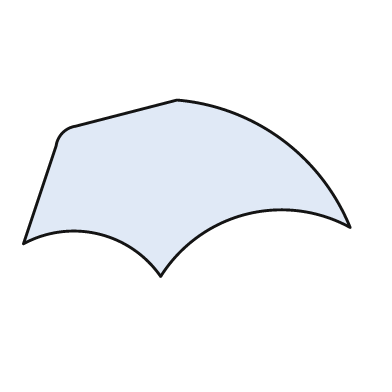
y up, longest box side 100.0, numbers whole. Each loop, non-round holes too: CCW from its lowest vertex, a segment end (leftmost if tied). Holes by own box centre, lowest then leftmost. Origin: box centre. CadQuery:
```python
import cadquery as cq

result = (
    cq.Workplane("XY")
    .moveTo(-8.0, -27.0)
    .threePointArc((18.0, -8.0), (50.0, -12.0))
    .threePointArc((29.0, 15.0), (-3.0, 27.0))
    .lineTo(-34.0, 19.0)
    .threePointArc((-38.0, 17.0), (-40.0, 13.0))
    .lineTo(-50.0, -17.0)
    .threePointArc((-27.0, -14.0), (-8.0, -27.0))
    .close()
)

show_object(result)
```